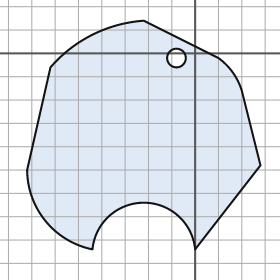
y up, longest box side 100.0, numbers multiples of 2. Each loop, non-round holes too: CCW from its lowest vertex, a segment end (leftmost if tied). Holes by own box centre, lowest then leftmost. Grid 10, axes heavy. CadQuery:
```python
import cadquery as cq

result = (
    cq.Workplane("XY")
    .moveTo(-44.0, -84.0)
    .threePointArc((-22.0, -64.0), (0.0, -84.0))
    .lineTo(28.0, -48.0)
    .lineTo(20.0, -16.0)
    .threePointArc((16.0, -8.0), (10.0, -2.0))
    .lineTo(-22.0, 14.0)
    .threePointArc((-44.0, 8.0), (-62.0, -6.0))
    .lineTo(-72.0, -50.0)
    .threePointArc((-64.0, -72.0), (-44.0, -84.0))
    .close()
    .moveTo(-8.0, -2.0)
    .circle(4.0)
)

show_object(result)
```